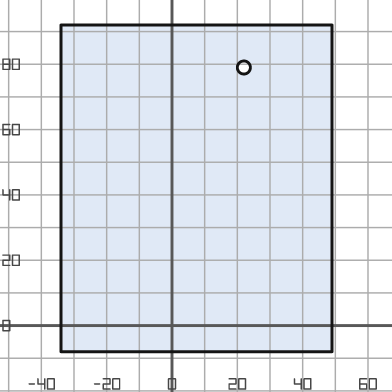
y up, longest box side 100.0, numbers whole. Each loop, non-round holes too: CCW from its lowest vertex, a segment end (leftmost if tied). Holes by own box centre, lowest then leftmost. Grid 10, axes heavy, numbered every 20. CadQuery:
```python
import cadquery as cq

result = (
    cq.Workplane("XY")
    .moveTo(-34.0, -8.0)
    .lineTo(49.0, -8.0)
    .lineTo(49.0, 92.0)
    .lineTo(-34.0, 92.0)
    .close()
    .moveTo(22.0, 79.0)
    .circle(2.0)
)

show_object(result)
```